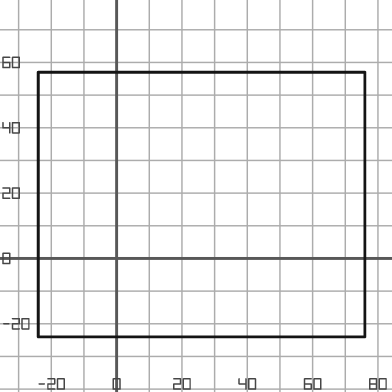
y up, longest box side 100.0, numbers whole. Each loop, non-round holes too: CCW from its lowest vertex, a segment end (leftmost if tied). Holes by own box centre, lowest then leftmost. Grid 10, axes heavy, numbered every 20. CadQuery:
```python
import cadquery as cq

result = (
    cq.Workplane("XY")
    .moveTo(-24.0, -24.0)
    .lineTo(76.0, -24.0)
    .lineTo(76.0, 57.0)
    .lineTo(-24.0, 57.0)
    .close()
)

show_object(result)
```